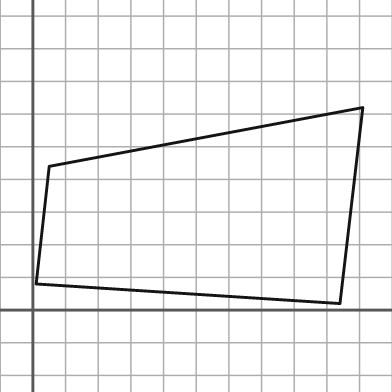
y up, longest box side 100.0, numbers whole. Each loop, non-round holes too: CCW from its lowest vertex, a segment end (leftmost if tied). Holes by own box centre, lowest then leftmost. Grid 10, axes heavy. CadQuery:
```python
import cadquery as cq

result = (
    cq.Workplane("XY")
    .moveTo(94.0, 2.0)
    .lineTo(101.0, 62.0)
    .lineTo(5.0, 44.0)
    .lineTo(1.0, 8.0)
    .close()
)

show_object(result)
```